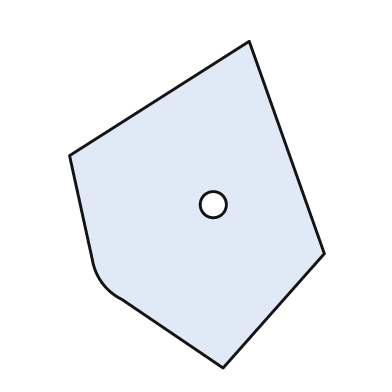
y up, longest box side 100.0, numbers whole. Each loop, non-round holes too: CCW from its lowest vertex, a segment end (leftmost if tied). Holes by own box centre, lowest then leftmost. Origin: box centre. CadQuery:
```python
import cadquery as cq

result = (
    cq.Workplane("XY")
    .moveTo(8.0, -50.0)
    .lineTo(39.0, -15.0)
    .lineTo(16.0, 50.0)
    .lineTo(-39.0, 15.0)
    .lineTo(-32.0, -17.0)
    .threePointArc((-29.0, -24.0), (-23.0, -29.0))
    .close()
    .moveTo(5.0, 0.0)
    .circle(4.0)
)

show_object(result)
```